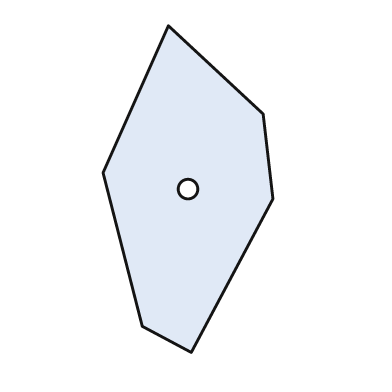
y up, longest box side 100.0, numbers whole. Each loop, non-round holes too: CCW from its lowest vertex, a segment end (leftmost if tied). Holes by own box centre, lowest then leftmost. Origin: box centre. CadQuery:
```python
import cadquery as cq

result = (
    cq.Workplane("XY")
    .moveTo(1.0, -50.0)
    .lineTo(26.0, -3.0)
    .lineTo(23.0, 23.0)
    .lineTo(-6.0, 50.0)
    .lineTo(-26.0, 5.0)
    .lineTo(-14.0, -42.0)
    .close()
    .moveTo(0.0, 0.0)
    .circle(3.0)
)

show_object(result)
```